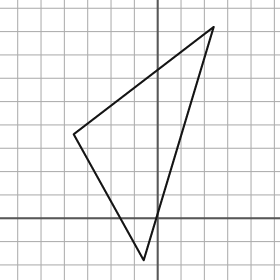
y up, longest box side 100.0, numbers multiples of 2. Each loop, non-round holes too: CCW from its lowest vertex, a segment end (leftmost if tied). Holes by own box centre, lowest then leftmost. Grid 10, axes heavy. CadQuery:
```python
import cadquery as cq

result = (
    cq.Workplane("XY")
    .moveTo(-6.0, -18.0)
    .lineTo(24.0, 82.0)
    .lineTo(-36.0, 36.0)
    .close()
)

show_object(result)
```